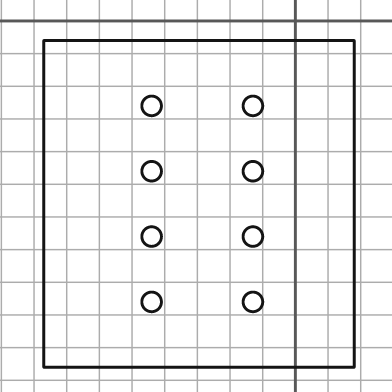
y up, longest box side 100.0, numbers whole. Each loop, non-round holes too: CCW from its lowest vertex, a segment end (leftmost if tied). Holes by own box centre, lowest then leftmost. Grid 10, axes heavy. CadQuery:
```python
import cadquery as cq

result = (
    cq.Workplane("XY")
    .moveTo(-77.0, -106.0)
    .lineTo(18.0, -106.0)
    .lineTo(18.0, -6.0)
    .lineTo(-77.0, -6.0)
    .close()
    .moveTo(-44.0, -86.0)
    .circle(3.0)
    .moveTo(-13.0, -86.0)
    .circle(3.0)
    .moveTo(-44.0, -66.0)
    .circle(3.0)
    .moveTo(-13.0, -66.0)
    .circle(3.0)
    .moveTo(-44.0, -46.0)
    .circle(3.0)
    .moveTo(-13.0, -46.0)
    .circle(3.0)
    .moveTo(-44.0, -26.0)
    .circle(3.0)
    .moveTo(-13.0, -26.0)
    .circle(3.0)
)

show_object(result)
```